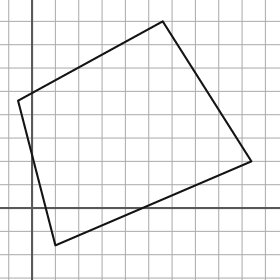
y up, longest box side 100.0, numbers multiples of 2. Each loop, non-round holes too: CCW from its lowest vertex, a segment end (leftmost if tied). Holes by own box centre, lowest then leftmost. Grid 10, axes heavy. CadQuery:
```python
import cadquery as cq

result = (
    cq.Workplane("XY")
    .moveTo(10.0, -16.0)
    .lineTo(94.0, 20.0)
    .lineTo(56.0, 80.0)
    .lineTo(-6.0, 46.0)
    .close()
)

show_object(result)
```